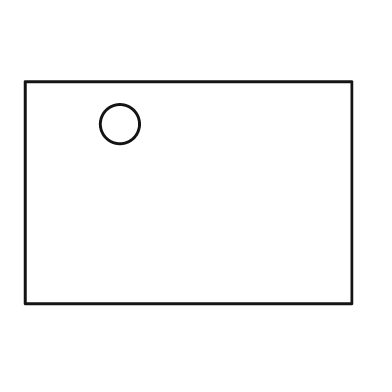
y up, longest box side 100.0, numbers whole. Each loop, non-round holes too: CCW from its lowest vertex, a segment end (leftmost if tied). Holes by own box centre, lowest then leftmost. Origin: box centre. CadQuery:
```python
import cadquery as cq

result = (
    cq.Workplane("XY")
    .moveTo(-50.0, -34.0)
    .lineTo(50.0, -34.0)
    .lineTo(50.0, 34.0)
    .lineTo(-50.0, 34.0)
    .close()
    .moveTo(-21.0, 21.0)
    .circle(6.0)
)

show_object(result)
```